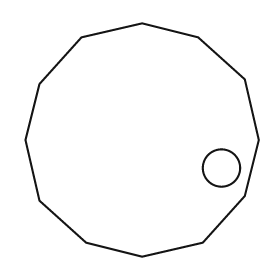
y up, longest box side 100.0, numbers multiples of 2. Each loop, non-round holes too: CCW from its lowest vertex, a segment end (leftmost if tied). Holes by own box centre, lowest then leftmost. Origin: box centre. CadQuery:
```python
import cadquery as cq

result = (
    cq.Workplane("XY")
    .moveTo(0.0, -50.0)
    .lineTo(26.0, -44.0)
    .lineTo(44.0, -24.0)
    .lineTo(50.0, 0.0)
    .lineTo(44.0, 26.0)
    .lineTo(24.0, 44.0)
    .lineTo(0.0, 50.0)
    .lineTo(-26.0, 44.0)
    .lineTo(-44.0, 24.0)
    .lineTo(-50.0, 0.0)
    .lineTo(-44.0, -26.0)
    .lineTo(-24.0, -44.0)
    .close()
    .moveTo(34.0, -12.0)
    .circle(8.0)
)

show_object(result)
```